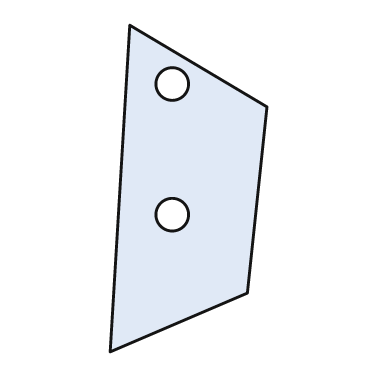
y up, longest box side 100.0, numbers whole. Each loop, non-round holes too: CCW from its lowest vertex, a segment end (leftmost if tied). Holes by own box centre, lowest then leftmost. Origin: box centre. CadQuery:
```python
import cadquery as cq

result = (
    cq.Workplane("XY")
    .moveTo(-24.0, -50.0)
    .lineTo(18.0, -32.0)
    .lineTo(24.0, 25.0)
    .lineTo(-18.0, 50.0)
    .close()
    .moveTo(-5.0, -8.0)
    .circle(5.0)
    .moveTo(-5.0, 32.0)
    .circle(5.0)
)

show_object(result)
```